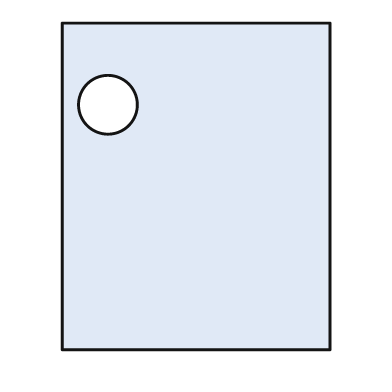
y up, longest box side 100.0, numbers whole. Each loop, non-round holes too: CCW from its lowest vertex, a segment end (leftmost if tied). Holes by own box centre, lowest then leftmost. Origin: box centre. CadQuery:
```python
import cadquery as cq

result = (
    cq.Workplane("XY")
    .moveTo(-41.0, -50.0)
    .lineTo(41.0, -50.0)
    .lineTo(41.0, 50.0)
    .lineTo(-41.0, 50.0)
    .close()
    .moveTo(-27.0, 25.0)
    .circle(9.0)
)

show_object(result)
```